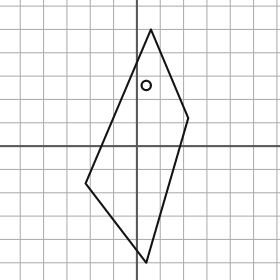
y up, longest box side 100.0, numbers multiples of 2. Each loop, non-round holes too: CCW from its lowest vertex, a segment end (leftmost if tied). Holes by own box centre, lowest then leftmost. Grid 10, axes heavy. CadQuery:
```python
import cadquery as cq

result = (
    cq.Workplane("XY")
    .moveTo(4.0, -50.0)
    .lineTo(22.0, 12.0)
    .lineTo(6.0, 50.0)
    .lineTo(-22.0, -16.0)
    .close()
    .moveTo(4.0, 26.0)
    .circle(2.0)
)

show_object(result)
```